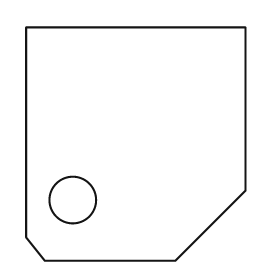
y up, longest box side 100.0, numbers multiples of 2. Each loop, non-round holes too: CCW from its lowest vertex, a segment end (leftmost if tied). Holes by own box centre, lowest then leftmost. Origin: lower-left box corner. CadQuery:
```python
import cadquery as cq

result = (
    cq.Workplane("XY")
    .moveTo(8.0, 0.0)
    .lineTo(64.0, 0.0)
    .lineTo(94.0, 30.0)
    .lineTo(94.0, 100.0)
    .lineTo(0.0, 100.0)
    .lineTo(0.0, 10.0)
    .close()
    .moveTo(20.0, 26.0)
    .circle(10.0)
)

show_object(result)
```